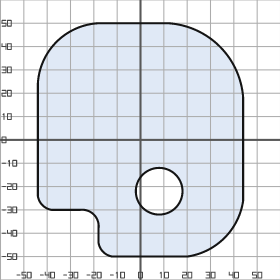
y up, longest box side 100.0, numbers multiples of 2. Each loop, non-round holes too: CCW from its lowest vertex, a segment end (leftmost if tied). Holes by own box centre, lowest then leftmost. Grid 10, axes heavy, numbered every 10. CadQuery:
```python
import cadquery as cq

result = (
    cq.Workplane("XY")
    .moveTo(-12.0, -50.0)
    .lineTo(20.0, -50.0)
    .threePointArc((36.0, -42.0), (44.0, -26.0))
    .lineTo(44.0, 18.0)
    .threePointArc((34.0, 40.0), (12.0, 50.0))
    .lineTo(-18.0, 50.0)
    .threePointArc((-36.0, 42.0), (-44.0, 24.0))
    .lineTo(-44.0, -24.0)
    .threePointArc((-42.0, -28.0), (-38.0, -30.0))
    .lineTo(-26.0, -30.0)
    .threePointArc((-20.0, -32.0), (-18.0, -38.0))
    .lineTo(-18.0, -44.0)
    .threePointArc((-16.0, -48.0), (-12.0, -50.0))
    .close()
    .moveTo(8.0, -22.0)
    .circle(10.0)
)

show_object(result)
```